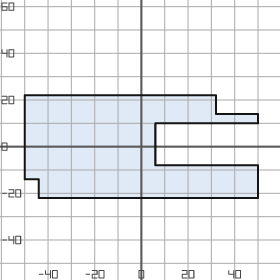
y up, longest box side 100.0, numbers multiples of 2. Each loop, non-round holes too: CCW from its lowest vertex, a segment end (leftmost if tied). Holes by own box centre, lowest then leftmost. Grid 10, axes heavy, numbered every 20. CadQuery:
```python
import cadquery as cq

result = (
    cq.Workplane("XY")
    .moveTo(-44.0, -22.0)
    .lineTo(50.0, -22.0)
    .lineTo(50.0, -8.0)
    .lineTo(6.0, -8.0)
    .lineTo(6.0, 10.0)
    .lineTo(50.0, 10.0)
    .lineTo(50.0, 14.0)
    .lineTo(32.0, 14.0)
    .lineTo(32.0, 22.0)
    .lineTo(-50.0, 22.0)
    .lineTo(-50.0, -14.0)
    .lineTo(-44.0, -14.0)
    .close()
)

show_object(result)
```